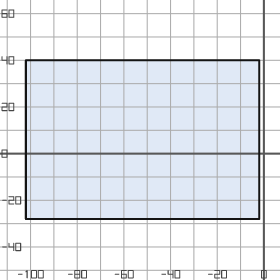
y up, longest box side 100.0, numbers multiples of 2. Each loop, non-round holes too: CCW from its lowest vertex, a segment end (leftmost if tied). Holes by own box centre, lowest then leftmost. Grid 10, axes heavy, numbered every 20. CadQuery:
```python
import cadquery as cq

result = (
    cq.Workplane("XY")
    .moveTo(-102.0, -28.0)
    .lineTo(-2.0, -28.0)
    .lineTo(-2.0, 40.0)
    .lineTo(-102.0, 40.0)
    .close()
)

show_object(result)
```